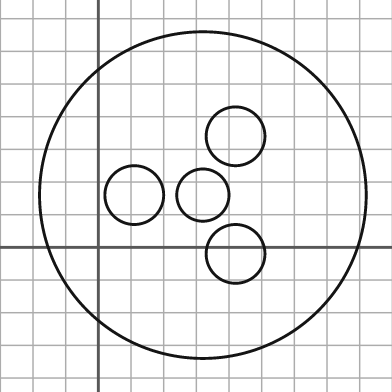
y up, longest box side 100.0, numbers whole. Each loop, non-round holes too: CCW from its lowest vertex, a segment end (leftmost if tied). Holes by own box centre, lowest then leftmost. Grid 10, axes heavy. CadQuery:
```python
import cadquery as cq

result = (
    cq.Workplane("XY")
    .moveTo(32.0, 16.0)
    .circle(50.0)
    .moveTo(42.0, -2.0)
    .circle(9.0)
    .moveTo(11.0, 16.0)
    .circle(9.0)
    .moveTo(32.0, 16.0)
    .circle(8.0)
    .moveTo(42.0, 34.0)
    .circle(9.0)
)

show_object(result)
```